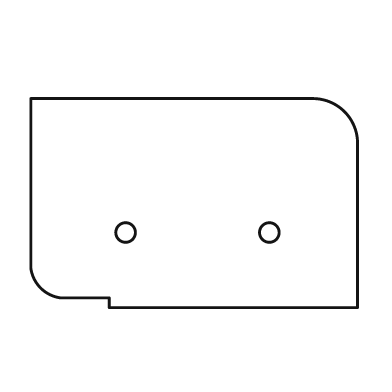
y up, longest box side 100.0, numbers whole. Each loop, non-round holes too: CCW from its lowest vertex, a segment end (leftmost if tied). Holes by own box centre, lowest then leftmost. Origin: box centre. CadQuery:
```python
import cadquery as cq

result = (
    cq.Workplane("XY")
    .moveTo(-26.0, -32.0)
    .lineTo(50.0, -32.0)
    .lineTo(50.0, 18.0)
    .threePointArc((46.0, 28.0), (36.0, 32.0))
    .lineTo(-50.0, 32.0)
    .lineTo(-50.0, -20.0)
    .threePointArc((-47.0, -26.0), (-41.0, -29.0))
    .lineTo(-26.0, -29.0)
    .close()
    .moveTo(-21.0, -9.0)
    .circle(3.0)
    .moveTo(23.0, -9.0)
    .circle(3.0)
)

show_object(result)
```